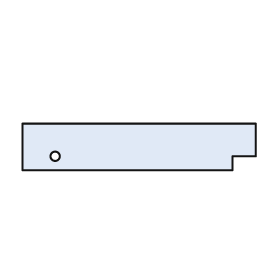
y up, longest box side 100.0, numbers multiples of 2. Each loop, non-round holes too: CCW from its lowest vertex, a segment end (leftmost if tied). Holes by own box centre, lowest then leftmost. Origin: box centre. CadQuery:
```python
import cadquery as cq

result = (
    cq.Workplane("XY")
    .moveTo(-50.0, -10.0)
    .lineTo(40.0, -10.0)
    .lineTo(40.0, -4.0)
    .lineTo(50.0, -4.0)
    .lineTo(50.0, 10.0)
    .lineTo(-50.0, 10.0)
    .close()
    .moveTo(-36.0, -4.0)
    .circle(2.0)
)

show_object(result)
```